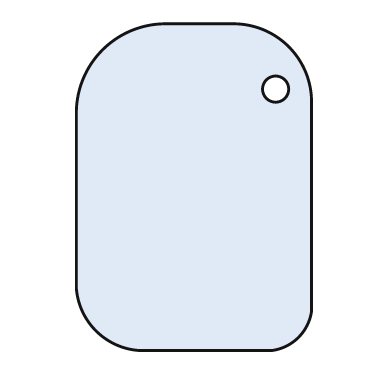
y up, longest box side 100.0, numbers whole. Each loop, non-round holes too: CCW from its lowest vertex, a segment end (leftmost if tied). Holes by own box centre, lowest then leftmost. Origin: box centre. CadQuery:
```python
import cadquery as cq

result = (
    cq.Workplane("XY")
    .moveTo(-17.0, -50.0)
    .lineTo(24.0, -50.0)
    .threePointArc((32.0, -46.0), (36.0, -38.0))
    .lineTo(36.0, 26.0)
    .threePointArc((29.0, 43.0), (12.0, 50.0))
    .lineTo(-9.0, 50.0)
    .threePointArc((-28.0, 42.0), (-36.0, 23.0))
    .lineTo(-36.0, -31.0)
    .threePointArc((-30.0, -44.0), (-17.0, -50.0))
    .close()
    .moveTo(25.0, 30.0)
    .circle(4.0)
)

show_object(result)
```